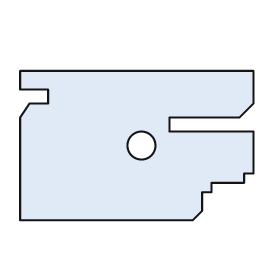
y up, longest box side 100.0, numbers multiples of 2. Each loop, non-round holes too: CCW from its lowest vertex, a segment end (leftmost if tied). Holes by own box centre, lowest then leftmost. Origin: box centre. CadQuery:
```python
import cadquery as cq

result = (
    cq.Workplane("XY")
    .moveTo(-50.0, -32.0)
    .lineTo(24.0, -32.0)
    .lineTo(28.0, -28.0)
    .lineTo(28.0, -20.0)
    .lineTo(32.0, -20.0)
    .lineTo(32.0, -16.0)
    .lineTo(46.0, -16.0)
    .lineTo(46.0, -12.0)
    .lineTo(50.0, -12.0)
    .lineTo(50.0, 6.0)
    .lineTo(14.0, 6.0)
    .lineTo(14.0, 12.0)
    .lineTo(44.0, 12.0)
    .lineTo(50.0, 18.0)
    .lineTo(50.0, 32.0)
    .lineTo(-50.0, 32.0)
    .lineTo(-50.0, 24.0)
    .lineTo(-38.0, 24.0)
    .lineTo(-38.0, 18.0)
    .lineTo(-46.0, 18.0)
    .lineTo(-50.0, 12.0)
    .close()
    .moveTo(2.0, 0.0)
    .circle(6.0)
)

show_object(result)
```